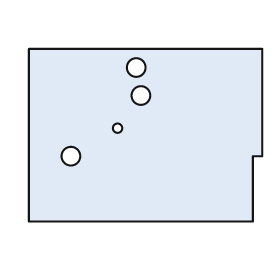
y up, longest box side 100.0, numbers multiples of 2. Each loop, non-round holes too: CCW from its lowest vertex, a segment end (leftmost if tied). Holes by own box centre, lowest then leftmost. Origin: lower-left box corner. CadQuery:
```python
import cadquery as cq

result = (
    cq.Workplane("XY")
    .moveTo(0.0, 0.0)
    .lineTo(96.0, 0.0)
    .lineTo(96.0, 28.0)
    .lineTo(100.0, 28.0)
    .lineTo(100.0, 74.0)
    .lineTo(0.0, 74.0)
    .close()
    .moveTo(18.0, 28.0)
    .circle(4.0)
    .moveTo(38.0, 40.0)
    .circle(2.0)
    .moveTo(48.0, 54.0)
    .circle(4.0)
    .moveTo(46.0, 66.0)
    .circle(4.0)
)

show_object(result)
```